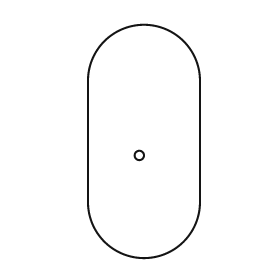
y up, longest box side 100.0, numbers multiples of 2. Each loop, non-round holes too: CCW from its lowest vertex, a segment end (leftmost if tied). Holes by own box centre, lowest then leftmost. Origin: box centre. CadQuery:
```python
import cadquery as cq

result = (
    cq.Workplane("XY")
    .moveTo(-24.0, -26.0)
    .threePointArc((0.0, -50.0), (24.0, -26.0))
    .lineTo(24.0, 26.0)
    .threePointArc((0.0, 50.0), (-24.0, 26.0))
    .close()
    .moveTo(-2.0, -6.0)
    .circle(2.0)
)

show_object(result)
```